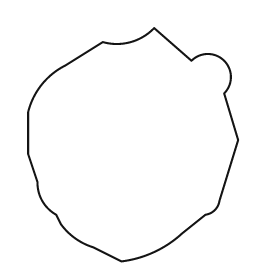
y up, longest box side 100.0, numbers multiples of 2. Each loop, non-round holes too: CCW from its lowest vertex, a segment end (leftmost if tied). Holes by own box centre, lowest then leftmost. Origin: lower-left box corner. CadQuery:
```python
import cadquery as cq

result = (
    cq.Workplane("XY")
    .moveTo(40.0, 0.0)
    .threePointArc((54.0, 4.0), (66.0, 12.0))
    .lineTo(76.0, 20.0)
    .threePointArc((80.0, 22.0), (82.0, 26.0))
    .lineTo(90.0, 52.0)
    .lineTo(84.0, 72.0)
    .threePointArc((84.0, 86.0), (70.0, 86.0))
    .lineTo(54.0, 100.0)
    .threePointArc((44.0, 94.0), (32.0, 94.0))
    .lineTo(16.0, 84.0)
    .threePointArc((6.0, 76.0), (0.0, 64.0))
    .lineTo(0.0, 46.0)
    .lineTo(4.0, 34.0)
    .threePointArc((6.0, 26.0), (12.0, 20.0))
    .lineTo(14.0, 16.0)
    .threePointArc((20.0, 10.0), (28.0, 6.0))
    .close()
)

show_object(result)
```